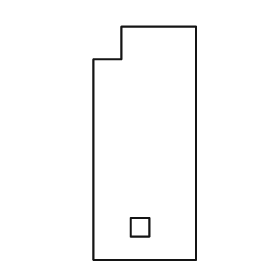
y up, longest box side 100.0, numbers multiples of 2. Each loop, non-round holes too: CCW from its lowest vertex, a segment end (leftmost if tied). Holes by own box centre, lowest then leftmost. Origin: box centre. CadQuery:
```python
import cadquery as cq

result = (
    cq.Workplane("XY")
    .moveTo(-22.0, -50.0)
    .lineTo(22.0, -50.0)
    .lineTo(22.0, 50.0)
    .lineTo(-10.0, 50.0)
    .lineTo(-10.0, 36.0)
    .lineTo(-22.0, 36.0)
    .close()
    .moveTo(-6.0, -40.0)
    .lineTo(2.0, -40.0)
    .lineTo(2.0, -32.0)
    .lineTo(-6.0, -32.0)
    .close()
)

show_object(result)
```